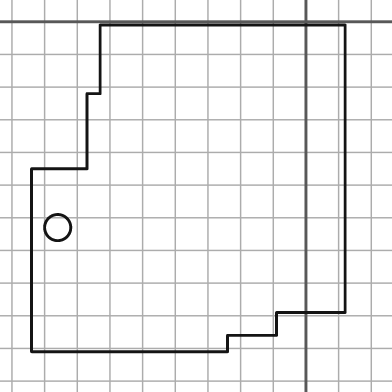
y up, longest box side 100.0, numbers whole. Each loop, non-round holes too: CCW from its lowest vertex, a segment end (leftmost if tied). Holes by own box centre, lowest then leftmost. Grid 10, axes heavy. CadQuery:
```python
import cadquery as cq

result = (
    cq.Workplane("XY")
    .moveTo(-84.0, -101.0)
    .lineTo(-24.0, -101.0)
    .lineTo(-24.0, -96.0)
    .lineTo(-9.0, -96.0)
    .lineTo(-9.0, -89.0)
    .lineTo(12.0, -89.0)
    .lineTo(12.0, -1.0)
    .lineTo(-63.0, -1.0)
    .lineTo(-63.0, -22.0)
    .lineTo(-67.0, -22.0)
    .lineTo(-67.0, -45.0)
    .lineTo(-84.0, -45.0)
    .close()
    .moveTo(-76.0, -63.0)
    .circle(4.0)
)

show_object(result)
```